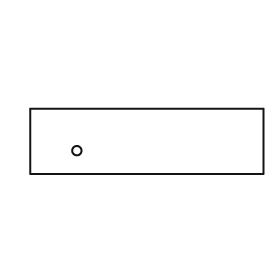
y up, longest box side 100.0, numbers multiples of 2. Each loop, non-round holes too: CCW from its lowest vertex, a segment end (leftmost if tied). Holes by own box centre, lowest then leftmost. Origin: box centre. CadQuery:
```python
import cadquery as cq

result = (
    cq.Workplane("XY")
    .moveTo(-50.0, -14.0)
    .lineTo(50.0, -14.0)
    .lineTo(50.0, 14.0)
    .lineTo(-50.0, 14.0)
    .close()
    .moveTo(-30.0, -4.0)
    .circle(2.0)
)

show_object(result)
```